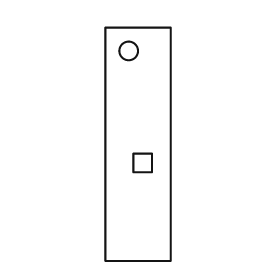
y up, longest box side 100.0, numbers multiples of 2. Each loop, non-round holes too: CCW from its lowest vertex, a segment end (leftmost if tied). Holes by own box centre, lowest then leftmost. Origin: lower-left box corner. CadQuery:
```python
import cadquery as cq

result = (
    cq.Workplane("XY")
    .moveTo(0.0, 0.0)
    .lineTo(28.0, 0.0)
    .lineTo(28.0, 100.0)
    .lineTo(0.0, 100.0)
    .close()
    .moveTo(12.0, 38.0)
    .lineTo(20.0, 38.0)
    .lineTo(20.0, 46.0)
    .lineTo(12.0, 46.0)
    .close()
    .moveTo(10.0, 90.0)
    .circle(4.0)
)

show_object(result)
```